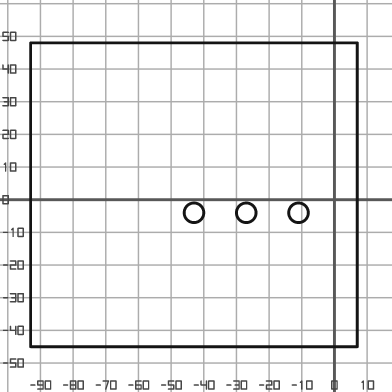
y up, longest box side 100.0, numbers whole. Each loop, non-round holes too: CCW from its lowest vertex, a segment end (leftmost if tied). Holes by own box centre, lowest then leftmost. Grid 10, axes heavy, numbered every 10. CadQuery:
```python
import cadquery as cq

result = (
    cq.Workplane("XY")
    .moveTo(-93.0, -45.0)
    .lineTo(7.0, -45.0)
    .lineTo(7.0, 48.0)
    .lineTo(-93.0, 48.0)
    .close()
    .moveTo(-43.0, -4.0)
    .circle(3.0)
    .moveTo(-27.0, -4.0)
    .circle(3.0)
    .moveTo(-11.0, -4.0)
    .circle(3.0)
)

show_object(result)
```